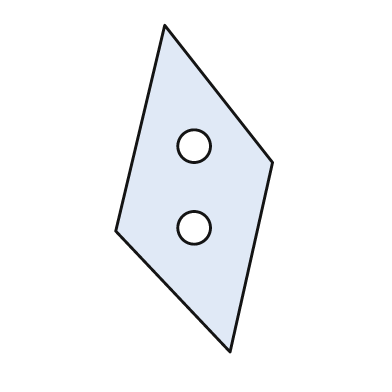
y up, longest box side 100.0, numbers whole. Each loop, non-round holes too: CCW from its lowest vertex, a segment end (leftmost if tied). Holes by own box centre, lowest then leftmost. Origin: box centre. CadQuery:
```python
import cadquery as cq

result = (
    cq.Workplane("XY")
    .moveTo(11.0, -50.0)
    .lineTo(24.0, 8.0)
    .lineTo(-9.0, 50.0)
    .lineTo(-24.0, -13.0)
    .close()
    .moveTo(0.0, -12.0)
    .circle(5.0)
    .moveTo(0.0, 13.0)
    .circle(5.0)
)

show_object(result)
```